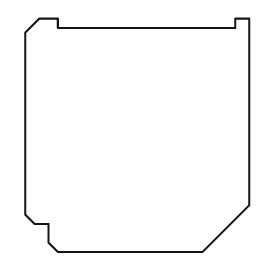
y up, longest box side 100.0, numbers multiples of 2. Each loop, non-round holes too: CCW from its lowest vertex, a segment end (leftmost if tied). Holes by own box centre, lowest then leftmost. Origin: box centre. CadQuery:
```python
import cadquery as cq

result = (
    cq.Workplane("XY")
    .moveTo(-34.0, -50.0)
    .lineTo(28.0, -50.0)
    .lineTo(48.0, -30.0)
    .lineTo(48.0, 50.0)
    .lineTo(42.0, 50.0)
    .lineTo(42.0, 46.0)
    .lineTo(-34.0, 46.0)
    .lineTo(-34.0, 50.0)
    .lineTo(-42.0, 50.0)
    .lineTo(-48.0, 44.0)
    .lineTo(-48.0, -34.0)
    .lineTo(-44.0, -38.0)
    .lineTo(-38.0, -38.0)
    .lineTo(-38.0, -46.0)
    .close()
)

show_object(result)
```